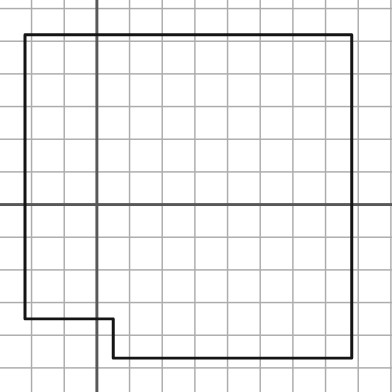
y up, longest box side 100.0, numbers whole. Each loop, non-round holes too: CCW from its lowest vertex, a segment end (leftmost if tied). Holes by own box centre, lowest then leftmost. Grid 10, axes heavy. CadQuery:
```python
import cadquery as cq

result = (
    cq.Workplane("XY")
    .moveTo(5.0, -47.0)
    .lineTo(78.0, -47.0)
    .lineTo(78.0, 52.0)
    .lineTo(-22.0, 52.0)
    .lineTo(-22.0, -35.0)
    .lineTo(5.0, -35.0)
    .close()
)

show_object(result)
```